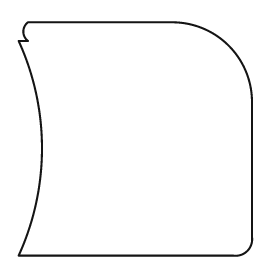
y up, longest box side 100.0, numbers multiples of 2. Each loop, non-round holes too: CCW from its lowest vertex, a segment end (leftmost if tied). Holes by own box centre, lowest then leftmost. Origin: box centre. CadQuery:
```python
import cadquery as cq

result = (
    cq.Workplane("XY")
    .moveTo(-50.0, -50.0)
    .lineTo(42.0, -50.0)
    .threePointArc((48.0, -48.0), (50.0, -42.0))
    .lineTo(50.0, 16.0)
    .threePointArc((40.0, 40.0), (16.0, 50.0))
    .lineTo(-46.0, 50.0)
    .threePointArc((-48.0, 46.0), (-46.0, 42.0))
    .lineTo(-50.0, 42.0)
    .threePointArc((-40.0, -4.0), (-50.0, -50.0))
    .close()
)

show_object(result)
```